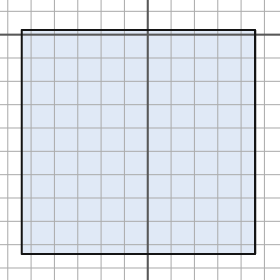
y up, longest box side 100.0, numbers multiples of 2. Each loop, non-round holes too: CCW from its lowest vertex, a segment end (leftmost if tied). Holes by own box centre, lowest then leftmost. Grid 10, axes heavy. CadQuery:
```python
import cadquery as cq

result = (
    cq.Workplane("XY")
    .moveTo(-54.0, -94.0)
    .lineTo(46.0, -94.0)
    .lineTo(46.0, 2.0)
    .lineTo(-54.0, 2.0)
    .close()
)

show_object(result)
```